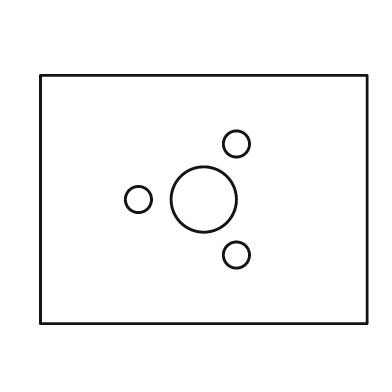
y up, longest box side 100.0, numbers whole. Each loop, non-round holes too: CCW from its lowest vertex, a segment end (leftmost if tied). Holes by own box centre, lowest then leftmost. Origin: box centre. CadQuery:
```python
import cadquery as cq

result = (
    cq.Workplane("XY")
    .moveTo(-50.0, -38.0)
    .lineTo(50.0, -38.0)
    .lineTo(50.0, 38.0)
    .lineTo(-50.0, 38.0)
    .close()
    .moveTo(10.0, -17.0)
    .circle(4.0)
    .moveTo(-20.0, 0.0)
    .circle(4.0)
    .moveTo(0.0, 0.0)
    .circle(10.0)
    .moveTo(10.0, 17.0)
    .circle(4.0)
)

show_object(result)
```